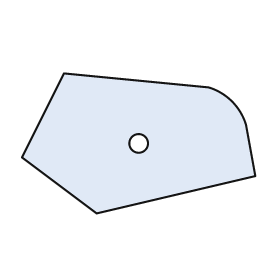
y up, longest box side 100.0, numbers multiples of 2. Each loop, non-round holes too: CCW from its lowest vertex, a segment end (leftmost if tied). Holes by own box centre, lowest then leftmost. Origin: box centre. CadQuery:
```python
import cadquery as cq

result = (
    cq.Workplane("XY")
    .moveTo(-18.0, -30.0)
    .lineTo(50.0, -14.0)
    .lineTo(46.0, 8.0)
    .threePointArc((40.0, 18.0), (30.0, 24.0))
    .lineTo(-32.0, 30.0)
    .lineTo(-50.0, -6.0)
    .close()
    .moveTo(0.0, 0.0)
    .circle(4.0)
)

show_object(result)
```